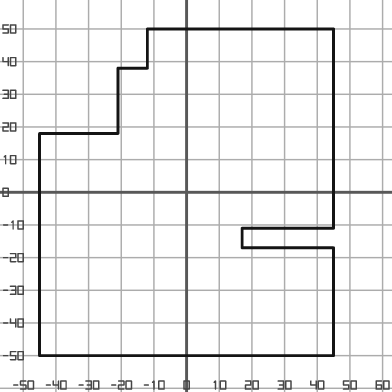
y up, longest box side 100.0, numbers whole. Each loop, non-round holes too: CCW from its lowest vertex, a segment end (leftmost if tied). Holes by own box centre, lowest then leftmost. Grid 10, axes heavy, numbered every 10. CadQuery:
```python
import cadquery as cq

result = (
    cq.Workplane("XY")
    .moveTo(-45.0, -50.0)
    .lineTo(45.0, -50.0)
    .lineTo(45.0, -17.0)
    .lineTo(17.0, -17.0)
    .lineTo(17.0, -11.0)
    .lineTo(45.0, -11.0)
    .lineTo(45.0, 50.0)
    .lineTo(-12.0, 50.0)
    .lineTo(-12.0, 38.0)
    .lineTo(-21.0, 38.0)
    .lineTo(-21.0, 18.0)
    .lineTo(-45.0, 18.0)
    .close()
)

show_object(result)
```